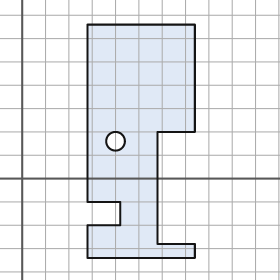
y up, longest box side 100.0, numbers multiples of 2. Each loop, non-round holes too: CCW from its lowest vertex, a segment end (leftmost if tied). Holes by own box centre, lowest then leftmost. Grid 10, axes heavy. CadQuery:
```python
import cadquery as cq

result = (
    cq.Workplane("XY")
    .moveTo(28.0, -34.0)
    .lineTo(74.0, -34.0)
    .lineTo(74.0, -28.0)
    .lineTo(58.0, -28.0)
    .lineTo(58.0, 20.0)
    .lineTo(74.0, 20.0)
    .lineTo(74.0, 66.0)
    .lineTo(28.0, 66.0)
    .lineTo(28.0, -10.0)
    .lineTo(42.0, -10.0)
    .lineTo(42.0, -20.0)
    .lineTo(28.0, -20.0)
    .close()
    .moveTo(40.0, 16.0)
    .circle(4.0)
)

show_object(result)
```